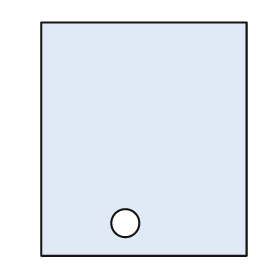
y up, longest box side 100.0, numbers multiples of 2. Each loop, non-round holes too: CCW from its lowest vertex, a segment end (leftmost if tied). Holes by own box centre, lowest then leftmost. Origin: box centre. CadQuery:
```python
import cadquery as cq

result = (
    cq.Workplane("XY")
    .moveTo(-44.0, -50.0)
    .lineTo(44.0, -50.0)
    .lineTo(44.0, 50.0)
    .lineTo(-44.0, 50.0)
    .close()
    .moveTo(-8.0, -36.0)
    .circle(6.0)
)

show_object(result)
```